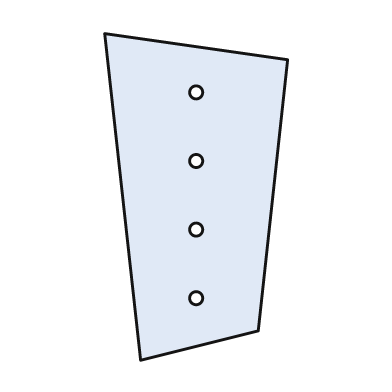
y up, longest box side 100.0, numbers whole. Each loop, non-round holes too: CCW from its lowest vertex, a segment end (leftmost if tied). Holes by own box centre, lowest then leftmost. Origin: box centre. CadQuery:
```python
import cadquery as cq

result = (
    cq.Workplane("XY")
    .moveTo(-17.0, -50.0)
    .lineTo(19.0, -41.0)
    .lineTo(28.0, 42.0)
    .lineTo(-28.0, 50.0)
    .close()
    .moveTo(0.0, -31.0)
    .circle(2.0)
    .moveTo(0.0, -10.0)
    .circle(2.0)
    .moveTo(0.0, 11.0)
    .circle(2.0)
    .moveTo(0.0, 32.0)
    .circle(2.0)
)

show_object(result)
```